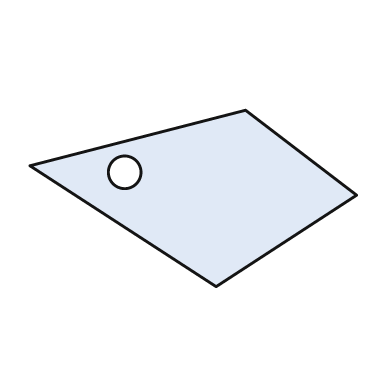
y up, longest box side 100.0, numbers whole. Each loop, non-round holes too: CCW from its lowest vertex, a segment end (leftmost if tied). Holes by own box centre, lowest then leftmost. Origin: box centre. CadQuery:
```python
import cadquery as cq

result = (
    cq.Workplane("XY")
    .moveTo(7.0, -27.0)
    .lineTo(50.0, 1.0)
    .lineTo(16.0, 27.0)
    .lineTo(-50.0, 10.0)
    .close()
    .moveTo(-21.0, 8.0)
    .circle(5.0)
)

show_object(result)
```